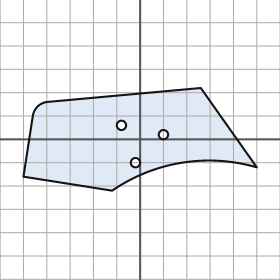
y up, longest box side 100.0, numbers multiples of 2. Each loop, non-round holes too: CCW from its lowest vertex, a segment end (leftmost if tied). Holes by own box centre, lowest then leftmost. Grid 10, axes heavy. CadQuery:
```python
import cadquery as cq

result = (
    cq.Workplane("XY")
    .moveTo(-12.0, -22.0)
    .threePointArc((18.0, -10.0), (50.0, -12.0))
    .lineTo(26.0, 22.0)
    .lineTo(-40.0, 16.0)
    .threePointArc((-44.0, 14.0), (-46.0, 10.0))
    .lineTo(-50.0, -16.0)
    .close()
    .moveTo(-2.0, -10.0)
    .circle(2.0)
    .moveTo(10.0, 2.0)
    .circle(2.0)
    .moveTo(-8.0, 6.0)
    .circle(2.0)
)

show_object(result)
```